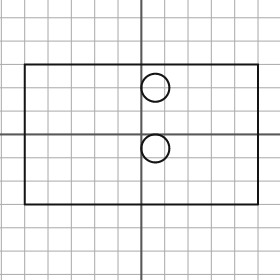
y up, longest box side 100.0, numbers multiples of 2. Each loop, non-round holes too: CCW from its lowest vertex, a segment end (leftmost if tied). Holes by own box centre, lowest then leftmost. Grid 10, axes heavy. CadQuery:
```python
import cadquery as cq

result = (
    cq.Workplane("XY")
    .moveTo(-50.0, -30.0)
    .lineTo(50.0, -30.0)
    .lineTo(50.0, 30.0)
    .lineTo(-50.0, 30.0)
    .close()
    .moveTo(6.0, -6.0)
    .circle(6.0)
    .moveTo(6.0, 20.0)
    .circle(6.0)
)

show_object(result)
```